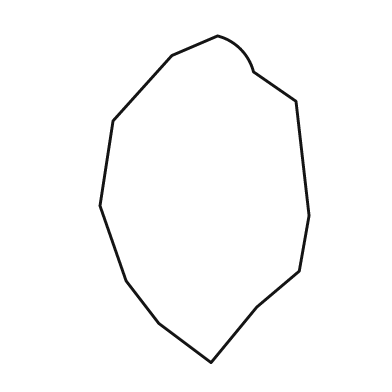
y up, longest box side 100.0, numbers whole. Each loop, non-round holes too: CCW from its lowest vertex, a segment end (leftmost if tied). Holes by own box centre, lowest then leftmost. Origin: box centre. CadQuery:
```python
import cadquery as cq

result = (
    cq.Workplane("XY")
    .moveTo(2.0, -50.0)
    .lineTo(16.0, -33.0)
    .lineTo(29.0, -22.0)
    .lineTo(32.0, -5.0)
    .lineTo(28.0, 30.0)
    .lineTo(15.0, 39.0)
    .threePointArc((11.0, 46.0), (4.0, 50.0))
    .lineTo(-10.0, 44.0)
    .lineTo(-28.0, 24.0)
    .lineTo(-32.0, -2.0)
    .lineTo(-24.0, -25.0)
    .lineTo(-14.0, -38.0)
    .close()
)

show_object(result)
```